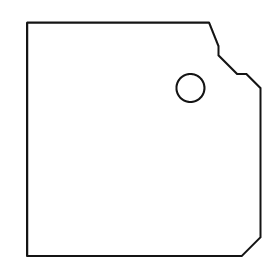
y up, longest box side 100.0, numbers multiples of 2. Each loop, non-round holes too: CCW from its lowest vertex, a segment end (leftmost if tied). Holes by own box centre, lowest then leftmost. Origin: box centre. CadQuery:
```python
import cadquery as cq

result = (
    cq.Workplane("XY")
    .moveTo(-50.0, -50.0)
    .lineTo(42.0, -50.0)
    .lineTo(50.0, -42.0)
    .lineTo(50.0, 22.0)
    .lineTo(44.0, 28.0)
    .lineTo(40.0, 28.0)
    .lineTo(32.0, 36.0)
    .lineTo(32.0, 40.0)
    .lineTo(28.0, 50.0)
    .lineTo(-50.0, 50.0)
    .close()
    .moveTo(20.0, 22.0)
    .circle(6.0)
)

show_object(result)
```